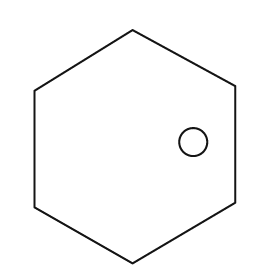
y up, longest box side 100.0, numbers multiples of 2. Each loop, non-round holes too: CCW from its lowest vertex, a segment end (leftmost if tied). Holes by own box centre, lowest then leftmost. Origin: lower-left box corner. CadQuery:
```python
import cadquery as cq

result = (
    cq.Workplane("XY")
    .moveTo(42.0, 0.0)
    .lineTo(86.0, 26.0)
    .lineTo(86.0, 76.0)
    .lineTo(42.0, 100.0)
    .lineTo(0.0, 74.0)
    .lineTo(0.0, 24.0)
    .close()
    .moveTo(68.0, 52.0)
    .circle(6.0)
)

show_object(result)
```